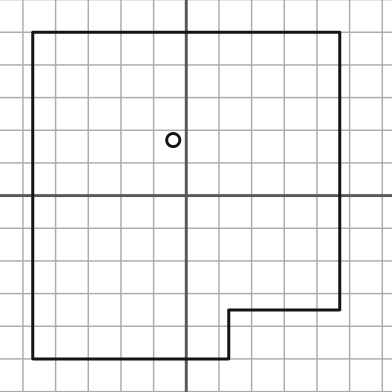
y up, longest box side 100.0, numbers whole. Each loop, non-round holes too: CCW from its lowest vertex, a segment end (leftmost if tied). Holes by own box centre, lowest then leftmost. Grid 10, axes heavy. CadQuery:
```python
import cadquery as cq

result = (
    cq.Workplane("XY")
    .moveTo(-47.0, -50.0)
    .lineTo(13.0, -50.0)
    .lineTo(13.0, -35.0)
    .lineTo(47.0, -35.0)
    .lineTo(47.0, 50.0)
    .lineTo(-47.0, 50.0)
    .close()
    .moveTo(-4.0, 17.0)
    .circle(2.0)
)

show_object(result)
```